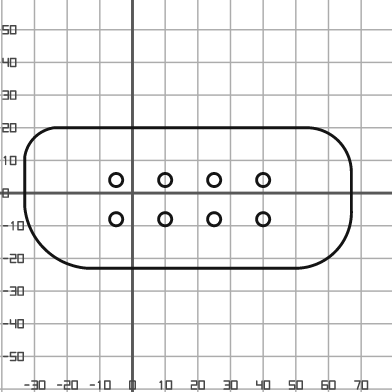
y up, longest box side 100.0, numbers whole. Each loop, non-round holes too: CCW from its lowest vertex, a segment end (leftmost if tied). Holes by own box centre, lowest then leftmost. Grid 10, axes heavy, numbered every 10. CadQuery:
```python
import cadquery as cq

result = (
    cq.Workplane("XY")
    .moveTo(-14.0, -23.0)
    .lineTo(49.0, -23.0)
    .threePointArc((62.0, -18.0), (67.0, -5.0))
    .lineTo(67.0, 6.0)
    .threePointArc((63.0, 16.0), (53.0, 20.0))
    .lineTo(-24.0, 20.0)
    .threePointArc((-30.0, 17.0), (-33.0, 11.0))
    .lineTo(-33.0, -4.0)
    .threePointArc((-27.0, -17.0), (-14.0, -23.0))
    .close()
    .moveTo(-5.0, -8.0)
    .circle(2.0)
    .moveTo(10.0, -8.0)
    .circle(2.0)
    .moveTo(25.0, -8.0)
    .circle(2.0)
    .moveTo(40.0, -8.0)
    .circle(2.0)
    .moveTo(-5.0, 4.0)
    .circle(2.0)
    .moveTo(10.0, 4.0)
    .circle(2.0)
    .moveTo(25.0, 4.0)
    .circle(2.0)
    .moveTo(40.0, 4.0)
    .circle(2.0)
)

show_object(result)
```